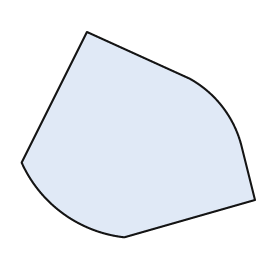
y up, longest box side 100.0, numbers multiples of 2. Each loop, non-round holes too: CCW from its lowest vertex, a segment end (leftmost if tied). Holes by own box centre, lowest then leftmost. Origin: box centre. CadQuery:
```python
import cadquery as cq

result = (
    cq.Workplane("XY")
    .moveTo(-6.0, -44.0)
    .lineTo(50.0, -28.0)
    .lineTo(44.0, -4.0)
    .threePointArc((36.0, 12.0), (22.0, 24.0))
    .lineTo(-22.0, 44.0)
    .lineTo(-50.0, -12.0)
    .threePointArc((-32.0, -34.0), (-6.0, -44.0))
    .close()
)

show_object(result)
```